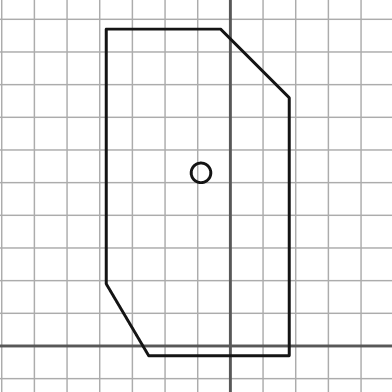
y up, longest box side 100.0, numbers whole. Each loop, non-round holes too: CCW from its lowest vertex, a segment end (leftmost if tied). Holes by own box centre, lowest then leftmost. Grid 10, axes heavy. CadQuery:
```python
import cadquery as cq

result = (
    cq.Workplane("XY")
    .moveTo(-25.0, -3.0)
    .lineTo(18.0, -3.0)
    .lineTo(18.0, 76.0)
    .lineTo(-3.0, 97.0)
    .lineTo(-38.0, 97.0)
    .lineTo(-38.0, 19.0)
    .close()
    .moveTo(-9.0, 53.0)
    .circle(3.0)
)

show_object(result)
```